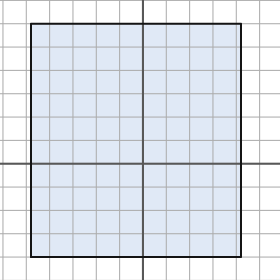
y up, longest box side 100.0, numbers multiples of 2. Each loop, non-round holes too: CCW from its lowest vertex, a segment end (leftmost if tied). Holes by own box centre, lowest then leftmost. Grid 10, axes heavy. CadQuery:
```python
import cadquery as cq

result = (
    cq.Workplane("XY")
    .moveTo(-48.0, -40.0)
    .lineTo(42.0, -40.0)
    .lineTo(42.0, 60.0)
    .lineTo(-48.0, 60.0)
    .close()
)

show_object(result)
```